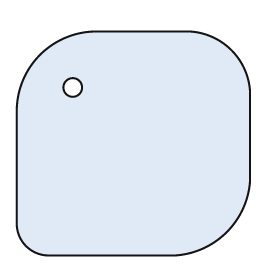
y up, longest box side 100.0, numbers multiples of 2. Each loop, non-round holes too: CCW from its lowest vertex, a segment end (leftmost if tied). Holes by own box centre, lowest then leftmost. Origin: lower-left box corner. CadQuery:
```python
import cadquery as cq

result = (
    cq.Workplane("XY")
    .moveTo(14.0, 0.0)
    .lineTo(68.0, 0.0)
    .threePointArc((90.0, 10.0), (100.0, 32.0))
    .lineTo(100.0, 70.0)
    .threePointArc((92.0, 88.0), (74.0, 96.0))
    .lineTo(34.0, 96.0)
    .threePointArc((10.0, 86.0), (0.0, 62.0))
    .lineTo(0.0, 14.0)
    .threePointArc((4.0, 4.0), (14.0, 0.0))
    .close()
    .moveTo(24.0, 72.0)
    .circle(4.0)
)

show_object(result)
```